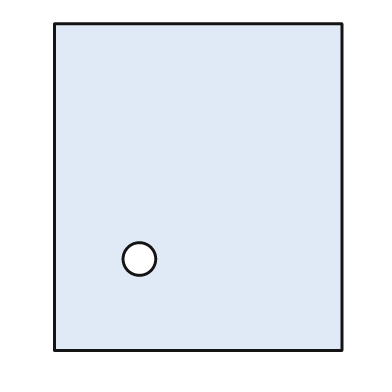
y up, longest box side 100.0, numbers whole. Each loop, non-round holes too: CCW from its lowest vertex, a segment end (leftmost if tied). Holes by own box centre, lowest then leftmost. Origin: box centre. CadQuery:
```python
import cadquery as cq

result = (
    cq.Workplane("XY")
    .moveTo(-44.0, -50.0)
    .lineTo(44.0, -50.0)
    .lineTo(44.0, 50.0)
    .lineTo(-44.0, 50.0)
    .close()
    .moveTo(-18.0, -22.0)
    .circle(5.0)
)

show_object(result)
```